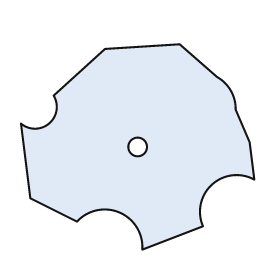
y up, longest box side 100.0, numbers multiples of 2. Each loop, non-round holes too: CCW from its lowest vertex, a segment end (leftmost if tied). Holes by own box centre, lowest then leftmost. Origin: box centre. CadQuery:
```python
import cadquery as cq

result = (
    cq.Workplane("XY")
    .moveTo(2.0, -44.0)
    .lineTo(28.0, -34.0)
    .threePointArc((32.0, -16.0), (50.0, -14.0))
    .lineTo(48.0, 2.0)
    .lineTo(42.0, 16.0)
    .threePointArc((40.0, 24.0), (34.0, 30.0))
    .lineTo(18.0, 44.0)
    .lineTo(-14.0, 42.0)
    .lineTo(-36.0, 22.0)
    .threePointArc((-38.0, 10.0), (-50.0, 10.0))
    .lineTo(-46.0, -22.0)
    .lineTo(-26.0, -32.0)
    .threePointArc((-8.0, -28.0), (2.0, -44.0))
    .close()
    .moveTo(0.0, 0.0)
    .circle(4.0)
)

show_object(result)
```